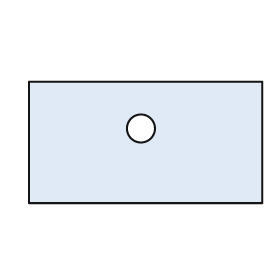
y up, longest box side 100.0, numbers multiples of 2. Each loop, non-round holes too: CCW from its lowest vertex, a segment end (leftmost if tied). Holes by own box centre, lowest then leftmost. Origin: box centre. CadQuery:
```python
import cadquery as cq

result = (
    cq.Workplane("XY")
    .moveTo(-50.0, -26.0)
    .lineTo(50.0, -26.0)
    .lineTo(50.0, 26.0)
    .lineTo(-50.0, 26.0)
    .close()
    .moveTo(-2.0, 6.0)
    .circle(6.0)
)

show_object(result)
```